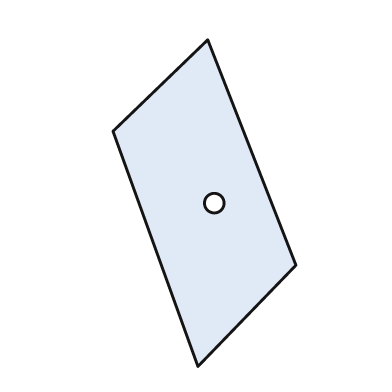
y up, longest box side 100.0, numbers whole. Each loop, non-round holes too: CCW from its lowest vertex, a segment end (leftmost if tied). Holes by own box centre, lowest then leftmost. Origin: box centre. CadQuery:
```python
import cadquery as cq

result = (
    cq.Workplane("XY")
    .moveTo(-2.0, -50.0)
    .lineTo(28.0, -19.0)
    .lineTo(1.0, 50.0)
    .lineTo(-28.0, 22.0)
    .close()
    .moveTo(3.0, 0.0)
    .circle(3.0)
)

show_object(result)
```